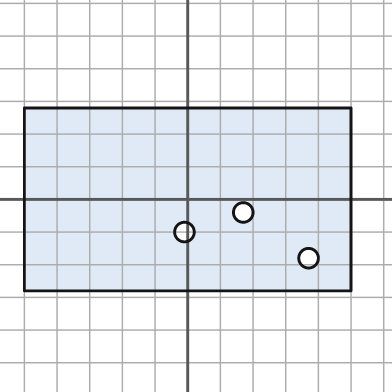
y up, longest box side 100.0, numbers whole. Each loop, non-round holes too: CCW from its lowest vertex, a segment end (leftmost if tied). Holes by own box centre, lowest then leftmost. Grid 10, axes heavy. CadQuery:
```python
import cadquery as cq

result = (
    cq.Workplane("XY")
    .moveTo(-50.0, -28.0)
    .lineTo(50.0, -28.0)
    .lineTo(50.0, 28.0)
    .lineTo(-50.0, 28.0)
    .close()
    .moveTo(37.0, -18.0)
    .circle(3.0)
    .moveTo(-1.0, -10.0)
    .circle(3.0)
    .moveTo(17.0, -4.0)
    .circle(3.0)
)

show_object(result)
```